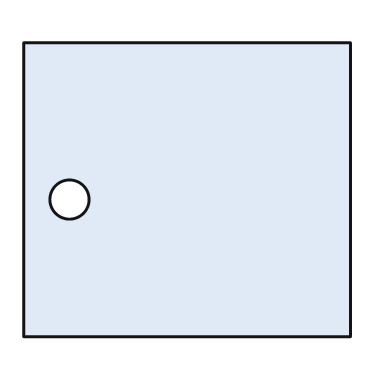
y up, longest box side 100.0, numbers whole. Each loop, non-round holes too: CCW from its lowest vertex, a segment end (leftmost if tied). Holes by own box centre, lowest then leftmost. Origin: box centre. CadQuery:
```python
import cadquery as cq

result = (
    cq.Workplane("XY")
    .moveTo(-50.0, -45.0)
    .lineTo(50.0, -45.0)
    .lineTo(50.0, 45.0)
    .lineTo(-50.0, 45.0)
    .close()
    .moveTo(-36.0, -3.0)
    .circle(6.0)
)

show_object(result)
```